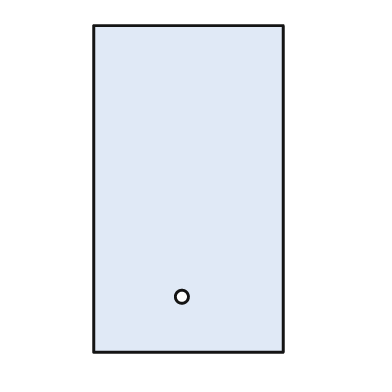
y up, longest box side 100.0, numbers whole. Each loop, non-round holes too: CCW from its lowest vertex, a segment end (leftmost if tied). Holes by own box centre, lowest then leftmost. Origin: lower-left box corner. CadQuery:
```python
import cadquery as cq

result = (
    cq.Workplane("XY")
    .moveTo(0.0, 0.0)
    .lineTo(58.0, 0.0)
    .lineTo(58.0, 100.0)
    .lineTo(0.0, 100.0)
    .close()
    .moveTo(27.0, 17.0)
    .circle(2.0)
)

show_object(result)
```